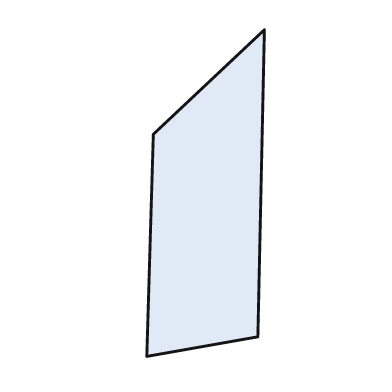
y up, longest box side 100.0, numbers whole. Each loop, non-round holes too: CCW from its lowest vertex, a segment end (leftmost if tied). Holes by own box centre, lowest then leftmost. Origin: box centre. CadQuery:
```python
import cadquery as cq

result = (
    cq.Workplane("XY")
    .moveTo(-18.0, -50.0)
    .lineTo(16.0, -44.0)
    .lineTo(18.0, 50.0)
    .lineTo(-16.0, 18.0)
    .close()
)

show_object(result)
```